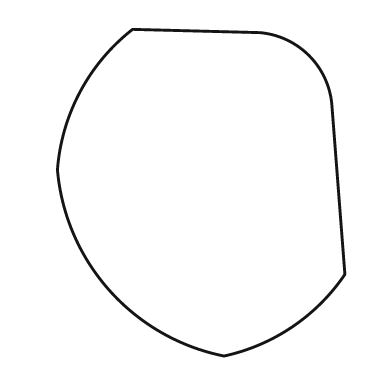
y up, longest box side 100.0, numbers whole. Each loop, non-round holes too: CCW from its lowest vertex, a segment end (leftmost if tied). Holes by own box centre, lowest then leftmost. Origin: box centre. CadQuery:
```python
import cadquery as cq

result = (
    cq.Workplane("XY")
    .moveTo(7.0, -50.0)
    .threePointArc((28.0, -41.0), (44.0, -25.0))
    .lineTo(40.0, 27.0)
    .threePointArc((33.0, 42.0), (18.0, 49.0))
    .lineTo(-21.0, 50.0)
    .threePointArc((-37.0, 31.0), (-44.0, 7.0))
    .threePointArc((-28.0, -30.0), (7.0, -50.0))
    .close()
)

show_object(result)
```